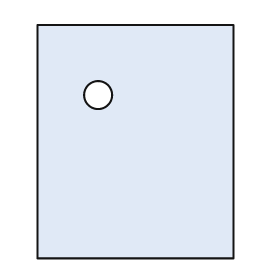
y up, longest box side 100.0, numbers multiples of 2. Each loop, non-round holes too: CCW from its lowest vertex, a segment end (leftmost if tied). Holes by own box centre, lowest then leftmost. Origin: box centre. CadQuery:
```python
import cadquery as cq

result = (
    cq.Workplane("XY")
    .moveTo(-42.0, -50.0)
    .lineTo(42.0, -50.0)
    .lineTo(42.0, 50.0)
    .lineTo(-42.0, 50.0)
    .close()
    .moveTo(-16.0, 20.0)
    .circle(6.0)
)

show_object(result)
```